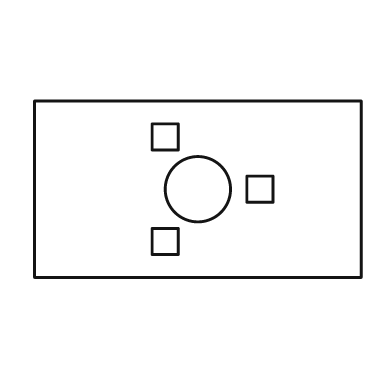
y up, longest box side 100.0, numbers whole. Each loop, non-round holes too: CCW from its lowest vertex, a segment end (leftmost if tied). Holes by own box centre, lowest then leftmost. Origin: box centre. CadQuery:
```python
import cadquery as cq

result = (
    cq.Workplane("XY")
    .moveTo(-50.0, -27.0)
    .lineTo(50.0, -27.0)
    .lineTo(50.0, 27.0)
    .lineTo(-50.0, 27.0)
    .close()
    .moveTo(-14.0, -20.0)
    .lineTo(-6.0, -20.0)
    .lineTo(-6.0, -12.0)
    .lineTo(-14.0, -12.0)
    .close()
    .moveTo(0.0, 0.0)
    .circle(10.0)
    .moveTo(15.0, -4.0)
    .lineTo(23.0, -4.0)
    .lineTo(23.0, 4.0)
    .lineTo(15.0, 4.0)
    .close()
    .moveTo(-14.0, 12.0)
    .lineTo(-6.0, 12.0)
    .lineTo(-6.0, 20.0)
    .lineTo(-14.0, 20.0)
    .close()
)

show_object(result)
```